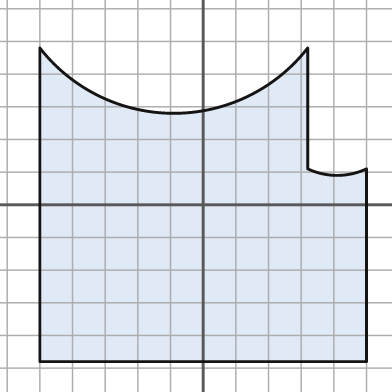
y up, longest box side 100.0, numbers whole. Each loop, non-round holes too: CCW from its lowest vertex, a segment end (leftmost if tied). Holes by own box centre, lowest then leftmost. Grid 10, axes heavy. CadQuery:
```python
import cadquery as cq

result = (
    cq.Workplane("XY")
    .moveTo(-50.0, -48.0)
    .lineTo(50.0, -48.0)
    .lineTo(50.0, 11.0)
    .threePointArc((41.0, 9.0), (32.0, 11.0))
    .lineTo(32.0, 48.0)
    .threePointArc((-9.0, 28.0), (-50.0, 48.0))
    .close()
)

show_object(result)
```